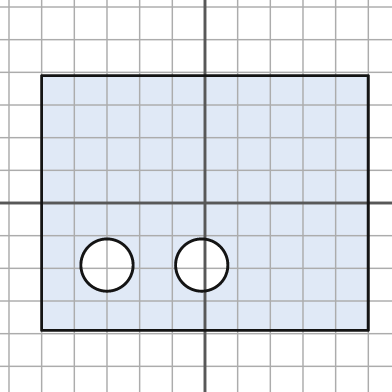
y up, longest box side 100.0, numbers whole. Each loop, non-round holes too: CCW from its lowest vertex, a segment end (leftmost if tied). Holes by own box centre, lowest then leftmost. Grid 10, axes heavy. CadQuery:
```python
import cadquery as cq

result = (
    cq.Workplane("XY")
    .moveTo(-50.0, -39.0)
    .lineTo(50.0, -39.0)
    .lineTo(50.0, 39.0)
    .lineTo(-50.0, 39.0)
    .close()
    .moveTo(-30.0, -19.0)
    .circle(8.0)
    .moveTo(-1.0, -19.0)
    .circle(8.0)
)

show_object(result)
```